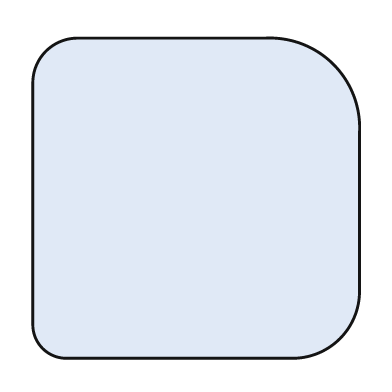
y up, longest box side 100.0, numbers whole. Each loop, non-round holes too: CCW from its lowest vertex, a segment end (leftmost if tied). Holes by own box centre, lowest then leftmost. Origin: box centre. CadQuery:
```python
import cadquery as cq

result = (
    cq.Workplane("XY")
    .moveTo(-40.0, -49.0)
    .lineTo(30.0, -49.0)
    .threePointArc((44.0, -43.0), (50.0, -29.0))
    .lineTo(50.0, 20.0)
    .threePointArc((42.0, 41.0), (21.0, 49.0))
    .lineTo(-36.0, 49.0)
    .threePointArc((-46.0, 45.0), (-50.0, 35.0))
    .lineTo(-50.0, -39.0)
    .threePointArc((-47.0, -46.0), (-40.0, -49.0))
    .close()
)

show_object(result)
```